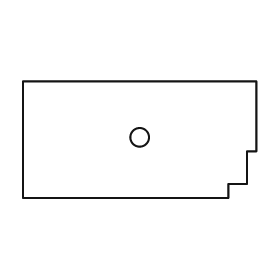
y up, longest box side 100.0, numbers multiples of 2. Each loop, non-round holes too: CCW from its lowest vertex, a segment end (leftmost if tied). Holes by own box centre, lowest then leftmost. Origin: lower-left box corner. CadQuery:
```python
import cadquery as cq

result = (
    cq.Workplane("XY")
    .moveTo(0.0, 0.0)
    .lineTo(88.0, 0.0)
    .lineTo(88.0, 6.0)
    .lineTo(96.0, 6.0)
    .lineTo(96.0, 20.0)
    .lineTo(100.0, 20.0)
    .lineTo(100.0, 50.0)
    .lineTo(0.0, 50.0)
    .close()
    .moveTo(50.0, 26.0)
    .circle(4.0)
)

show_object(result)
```